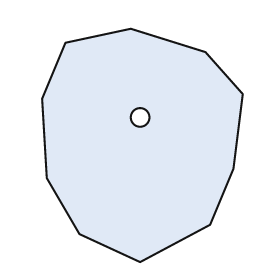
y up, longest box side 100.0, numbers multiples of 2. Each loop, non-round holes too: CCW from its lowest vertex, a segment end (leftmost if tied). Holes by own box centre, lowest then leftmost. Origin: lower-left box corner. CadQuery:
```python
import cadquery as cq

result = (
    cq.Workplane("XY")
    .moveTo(42.0, 0.0)
    .lineTo(72.0, 16.0)
    .lineTo(82.0, 40.0)
    .lineTo(86.0, 72.0)
    .lineTo(70.0, 90.0)
    .lineTo(38.0, 100.0)
    .lineTo(10.0, 94.0)
    .lineTo(0.0, 70.0)
    .lineTo(2.0, 36.0)
    .lineTo(16.0, 12.0)
    .close()
    .moveTo(42.0, 62.0)
    .circle(4.0)
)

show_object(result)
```